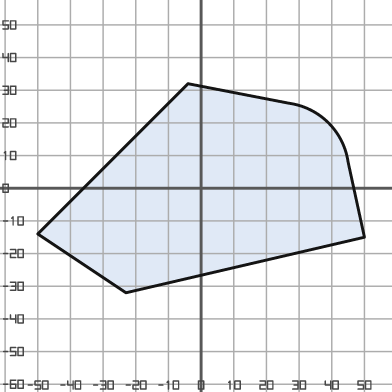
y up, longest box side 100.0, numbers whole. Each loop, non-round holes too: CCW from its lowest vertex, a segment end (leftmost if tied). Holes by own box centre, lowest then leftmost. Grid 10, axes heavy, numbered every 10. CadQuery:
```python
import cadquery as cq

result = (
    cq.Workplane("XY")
    .moveTo(-23.0, -32.0)
    .lineTo(50.0, -15.0)
    .lineTo(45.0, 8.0)
    .threePointArc((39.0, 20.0), (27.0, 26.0))
    .lineTo(-4.0, 32.0)
    .lineTo(-50.0, -14.0)
    .close()
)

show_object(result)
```